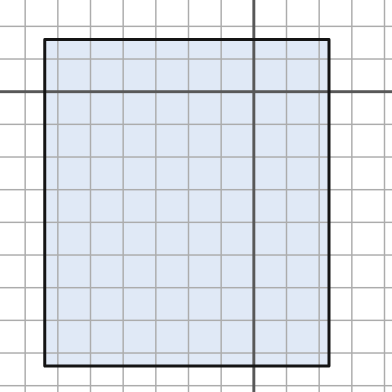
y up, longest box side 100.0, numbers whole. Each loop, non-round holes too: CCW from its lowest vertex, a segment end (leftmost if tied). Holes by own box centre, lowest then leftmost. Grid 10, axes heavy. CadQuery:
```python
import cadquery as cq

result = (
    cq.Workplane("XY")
    .moveTo(-64.0, -84.0)
    .lineTo(23.0, -84.0)
    .lineTo(23.0, 16.0)
    .lineTo(-64.0, 16.0)
    .close()
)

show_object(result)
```